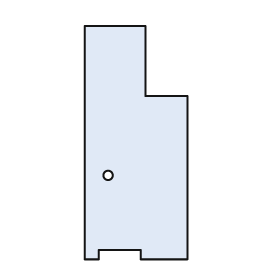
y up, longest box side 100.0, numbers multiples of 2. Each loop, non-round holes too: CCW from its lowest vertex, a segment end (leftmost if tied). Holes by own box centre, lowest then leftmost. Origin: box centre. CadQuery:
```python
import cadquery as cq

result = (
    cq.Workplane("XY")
    .moveTo(-22.0, -50.0)
    .lineTo(-16.0, -50.0)
    .lineTo(-16.0, -46.0)
    .lineTo(2.0, -46.0)
    .lineTo(2.0, -50.0)
    .lineTo(22.0, -50.0)
    .lineTo(22.0, 20.0)
    .lineTo(4.0, 20.0)
    .lineTo(4.0, 50.0)
    .lineTo(-22.0, 50.0)
    .close()
    .moveTo(-12.0, -14.0)
    .circle(2.0)
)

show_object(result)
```